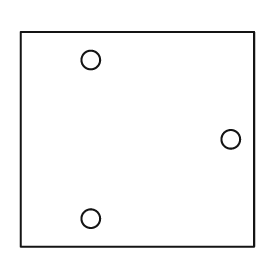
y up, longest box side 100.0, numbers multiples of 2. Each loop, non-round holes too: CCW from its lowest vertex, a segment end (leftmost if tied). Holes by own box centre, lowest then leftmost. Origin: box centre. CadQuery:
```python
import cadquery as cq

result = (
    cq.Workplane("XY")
    .moveTo(-50.0, -46.0)
    .lineTo(50.0, -46.0)
    .lineTo(50.0, 46.0)
    .lineTo(-50.0, 46.0)
    .close()
    .moveTo(-20.0, -34.0)
    .circle(4.0)
    .moveTo(40.0, 0.0)
    .circle(4.0)
    .moveTo(-20.0, 34.0)
    .circle(4.0)
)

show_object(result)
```